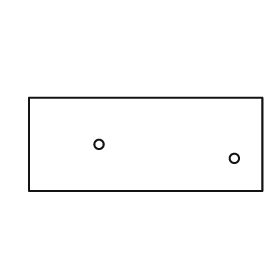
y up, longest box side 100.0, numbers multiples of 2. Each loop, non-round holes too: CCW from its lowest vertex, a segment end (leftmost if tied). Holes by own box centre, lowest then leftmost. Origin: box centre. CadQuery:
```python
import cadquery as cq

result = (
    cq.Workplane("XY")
    .moveTo(-50.0, -20.0)
    .lineTo(50.0, -20.0)
    .lineTo(50.0, 20.0)
    .lineTo(-50.0, 20.0)
    .close()
    .moveTo(38.0, -6.0)
    .circle(2.0)
    .moveTo(-20.0, 0.0)
    .circle(2.0)
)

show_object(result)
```